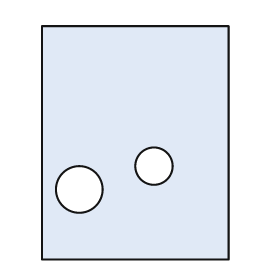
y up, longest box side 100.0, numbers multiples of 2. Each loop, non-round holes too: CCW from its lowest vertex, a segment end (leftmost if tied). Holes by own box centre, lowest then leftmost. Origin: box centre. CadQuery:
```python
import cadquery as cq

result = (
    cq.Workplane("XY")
    .moveTo(-40.0, -50.0)
    .lineTo(40.0, -50.0)
    .lineTo(40.0, 50.0)
    .lineTo(-40.0, 50.0)
    .close()
    .moveTo(-24.0, -20.0)
    .circle(10.0)
    .moveTo(8.0, -10.0)
    .circle(8.0)
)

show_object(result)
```